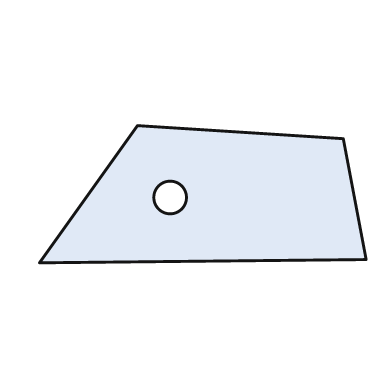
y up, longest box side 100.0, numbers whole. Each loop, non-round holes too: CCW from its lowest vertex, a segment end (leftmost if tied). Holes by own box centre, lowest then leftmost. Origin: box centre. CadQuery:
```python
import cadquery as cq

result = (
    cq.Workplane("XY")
    .moveTo(-50.0, -21.0)
    .lineTo(50.0, -20.0)
    .lineTo(43.0, 17.0)
    .lineTo(-20.0, 21.0)
    .close()
    .moveTo(-10.0, -1.0)
    .circle(5.0)
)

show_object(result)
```